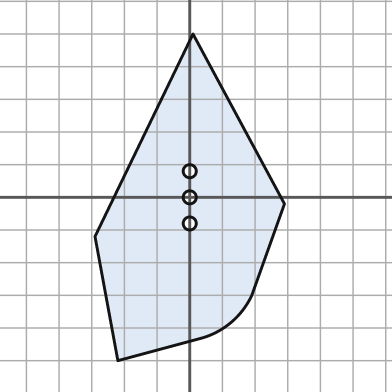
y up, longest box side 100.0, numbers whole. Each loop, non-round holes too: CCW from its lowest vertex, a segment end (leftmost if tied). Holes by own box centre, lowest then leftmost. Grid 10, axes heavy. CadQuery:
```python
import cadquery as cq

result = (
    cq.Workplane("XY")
    .moveTo(-22.0, -50.0)
    .lineTo(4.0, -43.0)
    .threePointArc((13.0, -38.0), (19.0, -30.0))
    .lineTo(29.0, -2.0)
    .lineTo(1.0, 50.0)
    .lineTo(-29.0, -12.0)
    .close()
    .moveTo(0.0, -8.0)
    .circle(2.0)
    .moveTo(0.0, 0.0)
    .circle(2.0)
    .moveTo(0.0, 8.0)
    .circle(2.0)
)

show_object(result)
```